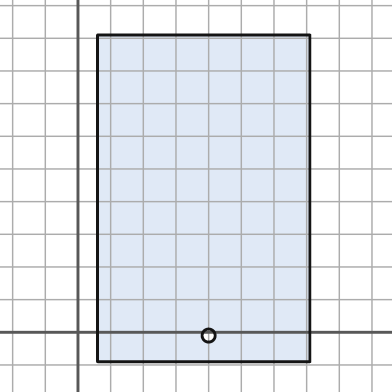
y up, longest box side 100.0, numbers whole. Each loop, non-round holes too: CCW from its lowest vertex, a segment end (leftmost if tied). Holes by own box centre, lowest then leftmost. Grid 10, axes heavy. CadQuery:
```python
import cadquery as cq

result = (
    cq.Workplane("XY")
    .moveTo(6.0, -9.0)
    .lineTo(71.0, -9.0)
    .lineTo(71.0, 91.0)
    .lineTo(6.0, 91.0)
    .close()
    .moveTo(40.0, -1.0)
    .circle(2.0)
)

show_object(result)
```